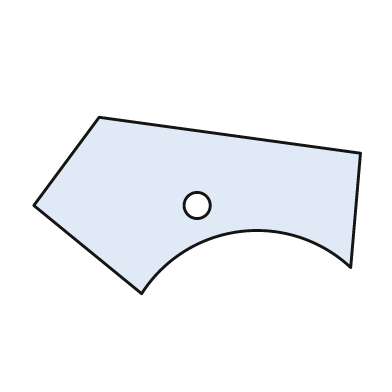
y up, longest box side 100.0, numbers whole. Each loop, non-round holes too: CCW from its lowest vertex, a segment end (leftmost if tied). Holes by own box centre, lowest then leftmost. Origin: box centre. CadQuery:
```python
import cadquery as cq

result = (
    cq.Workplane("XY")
    .moveTo(-17.0, -27.0)
    .threePointArc((13.0, -8.0), (47.0, -19.0))
    .lineTo(50.0, 16.0)
    .lineTo(-30.0, 27.0)
    .lineTo(-50.0, 0.0)
    .close()
    .moveTo(0.0, 0.0)
    .circle(4.0)
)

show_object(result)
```